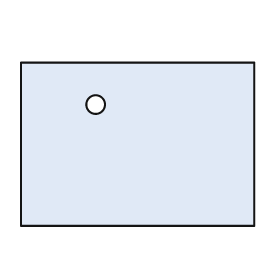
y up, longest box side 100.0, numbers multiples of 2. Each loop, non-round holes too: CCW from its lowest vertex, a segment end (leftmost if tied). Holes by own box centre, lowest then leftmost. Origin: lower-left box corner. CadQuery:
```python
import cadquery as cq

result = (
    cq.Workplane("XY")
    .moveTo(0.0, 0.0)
    .lineTo(100.0, 0.0)
    .lineTo(100.0, 70.0)
    .lineTo(0.0, 70.0)
    .close()
    .moveTo(32.0, 52.0)
    .circle(4.0)
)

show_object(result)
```